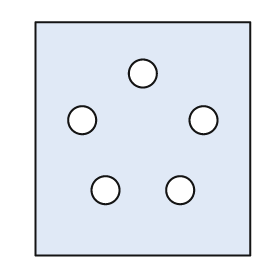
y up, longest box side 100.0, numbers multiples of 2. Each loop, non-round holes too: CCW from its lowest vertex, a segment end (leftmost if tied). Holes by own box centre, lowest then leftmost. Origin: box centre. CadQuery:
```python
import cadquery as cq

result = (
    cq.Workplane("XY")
    .moveTo(-46.0, -50.0)
    .lineTo(46.0, -50.0)
    .lineTo(46.0, 50.0)
    .lineTo(-46.0, 50.0)
    .close()
    .moveTo(-16.0, -22.0)
    .circle(6.0)
    .moveTo(16.0, -22.0)
    .circle(6.0)
    .moveTo(-26.0, 8.0)
    .circle(6.0)
    .moveTo(26.0, 8.0)
    .circle(6.0)
    .moveTo(0.0, 28.0)
    .circle(6.0)
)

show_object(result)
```